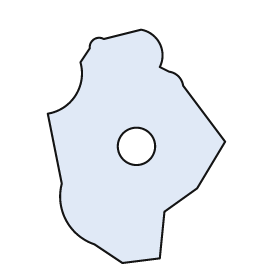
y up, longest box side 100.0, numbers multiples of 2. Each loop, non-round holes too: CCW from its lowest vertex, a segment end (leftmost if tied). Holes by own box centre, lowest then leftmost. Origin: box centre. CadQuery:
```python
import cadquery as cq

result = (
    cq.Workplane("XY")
    .moveTo(-6.0, -50.0)
    .lineTo(10.0, -48.0)
    .lineTo(12.0, -28.0)
    .lineTo(26.0, -18.0)
    .lineTo(38.0, 2.0)
    .lineTo(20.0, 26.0)
    .threePointArc((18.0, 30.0), (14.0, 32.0))
    .lineTo(10.0, 34.0)
    .threePointArc((10.0, 44.0), (2.0, 50.0))
    .lineTo(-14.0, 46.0)
    .threePointArc((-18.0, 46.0), (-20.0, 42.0))
    .lineTo(-24.0, 36.0)
    .threePointArc((-26.0, 22.0), (-38.0, 14.0))
    .lineTo(-32.0, -16.0)
    .threePointArc((-30.0, -32.0), (-18.0, -42.0))
    .close()
    .moveTo(0.0, 0.0)
    .circle(8.0)
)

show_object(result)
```